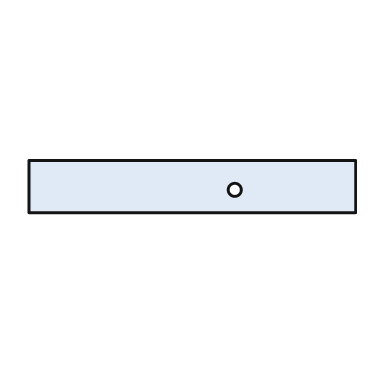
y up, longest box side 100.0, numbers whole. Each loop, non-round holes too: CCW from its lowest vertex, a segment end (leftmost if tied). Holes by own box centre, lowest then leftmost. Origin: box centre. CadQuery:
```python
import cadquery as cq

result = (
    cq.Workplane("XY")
    .moveTo(-50.0, -8.0)
    .lineTo(50.0, -8.0)
    .lineTo(50.0, 8.0)
    .lineTo(-50.0, 8.0)
    .close()
    .moveTo(13.0, -1.0)
    .circle(2.0)
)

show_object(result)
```